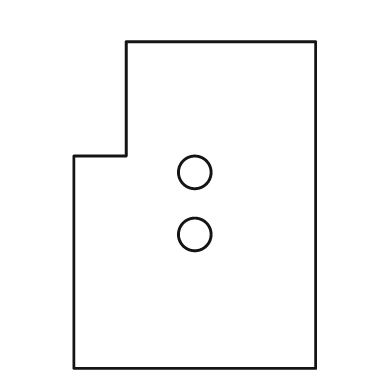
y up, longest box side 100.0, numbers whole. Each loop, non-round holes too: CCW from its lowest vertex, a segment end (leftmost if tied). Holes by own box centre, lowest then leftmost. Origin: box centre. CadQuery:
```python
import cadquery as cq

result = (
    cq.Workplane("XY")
    .moveTo(-37.0, -50.0)
    .lineTo(37.0, -50.0)
    .lineTo(37.0, 50.0)
    .lineTo(-21.0, 50.0)
    .lineTo(-21.0, 15.0)
    .lineTo(-37.0, 15.0)
    .close()
    .moveTo(0.0, -9.0)
    .circle(5.0)
    .moveTo(0.0, 10.0)
    .circle(5.0)
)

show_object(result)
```